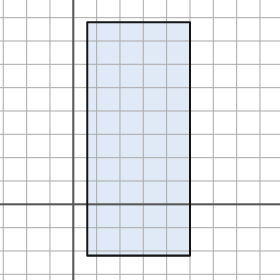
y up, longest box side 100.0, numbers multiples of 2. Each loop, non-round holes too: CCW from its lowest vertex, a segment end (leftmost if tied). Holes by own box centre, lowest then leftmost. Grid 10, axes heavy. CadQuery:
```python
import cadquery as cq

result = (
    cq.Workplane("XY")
    .moveTo(6.0, -22.0)
    .lineTo(50.0, -22.0)
    .lineTo(50.0, 78.0)
    .lineTo(6.0, 78.0)
    .close()
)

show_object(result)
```